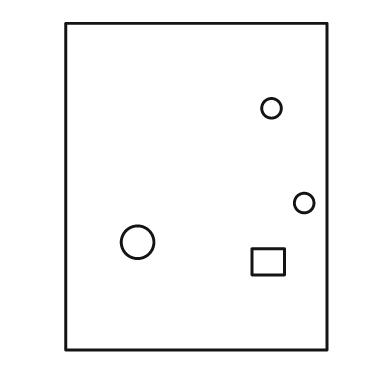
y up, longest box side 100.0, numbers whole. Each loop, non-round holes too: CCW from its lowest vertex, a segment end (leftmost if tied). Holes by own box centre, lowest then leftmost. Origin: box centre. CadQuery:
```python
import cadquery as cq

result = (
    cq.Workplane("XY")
    .moveTo(-40.0, -50.0)
    .lineTo(40.0, -50.0)
    .lineTo(40.0, 50.0)
    .lineTo(-40.0, 50.0)
    .close()
    .moveTo(17.0, -27.0)
    .lineTo(27.0, -27.0)
    .lineTo(27.0, -19.0)
    .lineTo(17.0, -19.0)
    .close()
    .moveTo(-18.0, -17.0)
    .circle(5.0)
    .moveTo(33.0, -5.0)
    .circle(3.0)
    .moveTo(23.0, 24.0)
    .circle(3.0)
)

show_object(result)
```